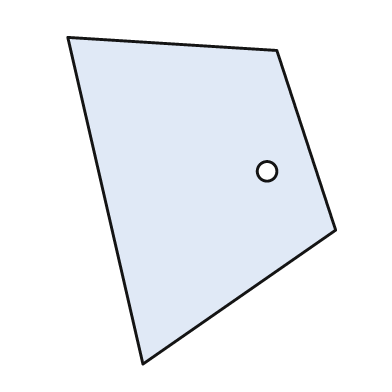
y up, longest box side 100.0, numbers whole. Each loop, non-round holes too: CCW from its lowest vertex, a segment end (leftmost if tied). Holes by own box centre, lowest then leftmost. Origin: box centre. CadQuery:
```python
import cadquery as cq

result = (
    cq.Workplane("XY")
    .moveTo(-18.0, -50.0)
    .lineTo(41.0, -9.0)
    .lineTo(23.0, 46.0)
    .lineTo(-41.0, 50.0)
    .close()
    .moveTo(20.0, 9.0)
    .circle(3.0)
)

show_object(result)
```